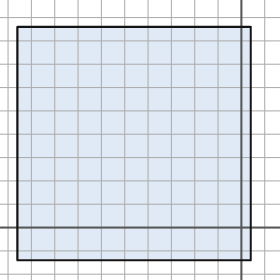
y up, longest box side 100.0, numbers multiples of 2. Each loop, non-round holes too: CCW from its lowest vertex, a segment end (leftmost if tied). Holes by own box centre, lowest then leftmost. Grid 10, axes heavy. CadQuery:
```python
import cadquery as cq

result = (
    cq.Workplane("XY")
    .moveTo(-96.0, -14.0)
    .lineTo(4.0, -14.0)
    .lineTo(4.0, 86.0)
    .lineTo(-96.0, 86.0)
    .close()
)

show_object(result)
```